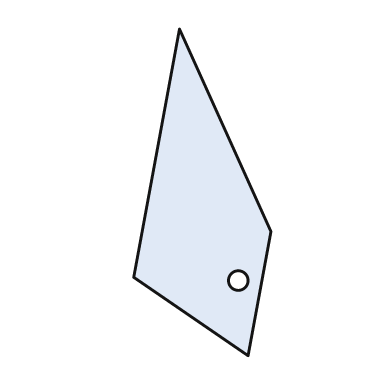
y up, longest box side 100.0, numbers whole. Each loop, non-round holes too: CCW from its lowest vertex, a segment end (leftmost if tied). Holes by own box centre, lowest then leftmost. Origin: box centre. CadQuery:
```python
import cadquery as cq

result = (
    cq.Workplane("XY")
    .moveTo(14.0, -50.0)
    .lineTo(21.0, -12.0)
    .lineTo(-7.0, 50.0)
    .lineTo(-21.0, -26.0)
    .close()
    .moveTo(11.0, -27.0)
    .circle(3.0)
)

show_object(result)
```